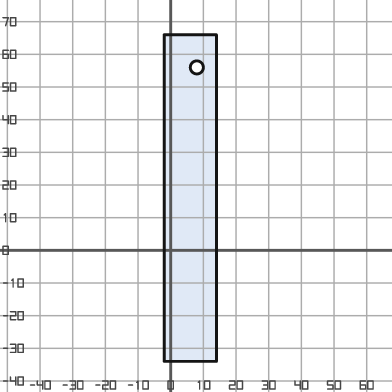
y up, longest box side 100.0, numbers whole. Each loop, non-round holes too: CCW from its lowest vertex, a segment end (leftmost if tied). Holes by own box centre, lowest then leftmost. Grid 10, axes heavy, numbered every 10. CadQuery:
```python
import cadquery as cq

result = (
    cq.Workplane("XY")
    .moveTo(-2.0, -34.0)
    .lineTo(14.0, -34.0)
    .lineTo(14.0, 66.0)
    .lineTo(-2.0, 66.0)
    .close()
    .moveTo(8.0, 56.0)
    .circle(2.0)
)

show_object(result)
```